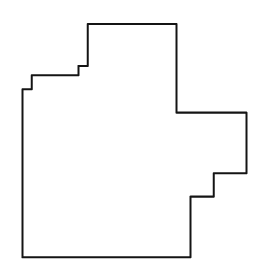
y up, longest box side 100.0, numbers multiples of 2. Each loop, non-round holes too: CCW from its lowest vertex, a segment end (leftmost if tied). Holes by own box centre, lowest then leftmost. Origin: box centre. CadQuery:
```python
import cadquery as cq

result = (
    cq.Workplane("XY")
    .moveTo(-48.0, -50.0)
    .lineTo(24.0, -50.0)
    .lineTo(24.0, -24.0)
    .lineTo(34.0, -24.0)
    .lineTo(34.0, -14.0)
    .lineTo(48.0, -14.0)
    .lineTo(48.0, 12.0)
    .lineTo(18.0, 12.0)
    .lineTo(18.0, 50.0)
    .lineTo(-20.0, 50.0)
    .lineTo(-20.0, 32.0)
    .lineTo(-24.0, 32.0)
    .lineTo(-24.0, 28.0)
    .lineTo(-44.0, 28.0)
    .lineTo(-44.0, 22.0)
    .lineTo(-48.0, 22.0)
    .close()
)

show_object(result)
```